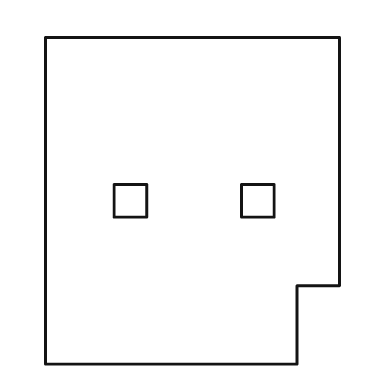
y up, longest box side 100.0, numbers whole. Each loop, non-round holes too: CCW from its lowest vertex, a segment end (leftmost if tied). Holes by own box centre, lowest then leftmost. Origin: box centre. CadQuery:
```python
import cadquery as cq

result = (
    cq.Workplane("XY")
    .moveTo(-45.0, -50.0)
    .lineTo(32.0, -50.0)
    .lineTo(32.0, -26.0)
    .lineTo(45.0, -26.0)
    .lineTo(45.0, 50.0)
    .lineTo(-45.0, 50.0)
    .close()
    .moveTo(-24.0, -5.0)
    .lineTo(-14.0, -5.0)
    .lineTo(-14.0, 5.0)
    .lineTo(-24.0, 5.0)
    .close()
    .moveTo(15.0, -5.0)
    .lineTo(25.0, -5.0)
    .lineTo(25.0, 5.0)
    .lineTo(15.0, 5.0)
    .close()
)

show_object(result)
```